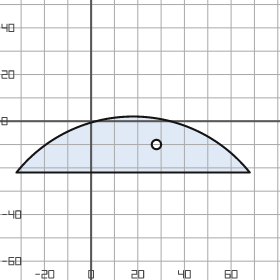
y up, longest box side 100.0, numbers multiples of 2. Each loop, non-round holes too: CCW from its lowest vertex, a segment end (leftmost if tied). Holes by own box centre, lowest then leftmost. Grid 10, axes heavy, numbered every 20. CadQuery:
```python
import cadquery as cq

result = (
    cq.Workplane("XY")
    .moveTo(-32.0, -22.0)
    .lineTo(68.0, -22.0)
    .threePointArc((18.0, 2.0), (-32.0, -22.0))
    .close()
    .moveTo(28.0, -10.0)
    .circle(2.0)
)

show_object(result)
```